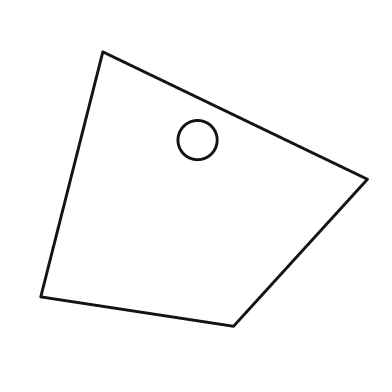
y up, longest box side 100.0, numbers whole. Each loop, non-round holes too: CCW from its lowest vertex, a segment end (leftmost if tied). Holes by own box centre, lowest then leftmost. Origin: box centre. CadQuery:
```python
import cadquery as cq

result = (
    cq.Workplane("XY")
    .moveTo(9.0, -42.0)
    .lineTo(50.0, 3.0)
    .lineTo(-31.0, 42.0)
    .lineTo(-50.0, -33.0)
    .close()
    .moveTo(-2.0, 15.0)
    .circle(6.0)
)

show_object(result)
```